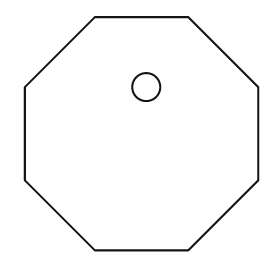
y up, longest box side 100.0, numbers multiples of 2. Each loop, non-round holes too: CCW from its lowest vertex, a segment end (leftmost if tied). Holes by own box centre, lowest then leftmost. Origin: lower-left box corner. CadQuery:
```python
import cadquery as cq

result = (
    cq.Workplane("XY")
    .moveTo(30.0, 0.0)
    .lineTo(70.0, 0.0)
    .lineTo(100.0, 30.0)
    .lineTo(100.0, 70.0)
    .lineTo(70.0, 100.0)
    .lineTo(30.0, 100.0)
    .lineTo(0.0, 70.0)
    .lineTo(0.0, 30.0)
    .close()
    .moveTo(52.0, 70.0)
    .circle(6.0)
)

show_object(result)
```